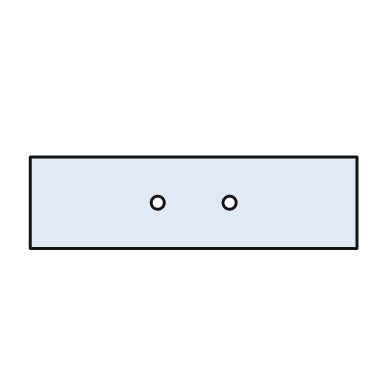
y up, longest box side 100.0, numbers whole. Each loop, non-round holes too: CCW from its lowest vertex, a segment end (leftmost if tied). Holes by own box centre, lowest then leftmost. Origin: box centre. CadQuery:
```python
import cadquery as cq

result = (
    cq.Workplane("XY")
    .moveTo(-50.0, -14.0)
    .lineTo(50.0, -14.0)
    .lineTo(50.0, 14.0)
    .lineTo(-50.0, 14.0)
    .close()
    .moveTo(-11.0, 0.0)
    .circle(2.0)
    .moveTo(11.0, 0.0)
    .circle(2.0)
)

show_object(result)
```